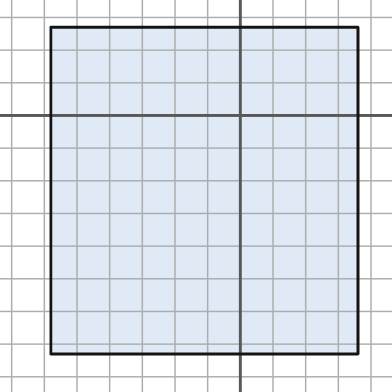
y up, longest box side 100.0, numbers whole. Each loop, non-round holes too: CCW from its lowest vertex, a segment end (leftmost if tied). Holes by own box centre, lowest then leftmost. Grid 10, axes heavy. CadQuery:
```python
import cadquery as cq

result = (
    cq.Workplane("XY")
    .moveTo(-58.0, -73.0)
    .lineTo(36.0, -73.0)
    .lineTo(36.0, 27.0)
    .lineTo(-58.0, 27.0)
    .close()
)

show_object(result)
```